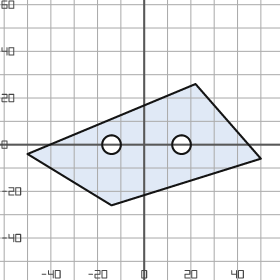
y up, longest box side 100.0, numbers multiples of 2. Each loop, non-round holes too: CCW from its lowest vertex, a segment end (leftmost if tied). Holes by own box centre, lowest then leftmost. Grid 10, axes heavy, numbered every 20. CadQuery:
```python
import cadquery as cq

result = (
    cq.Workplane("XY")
    .moveTo(-14.0, -26.0)
    .lineTo(50.0, -6.0)
    .lineTo(22.0, 26.0)
    .lineTo(-50.0, -4.0)
    .close()
    .moveTo(-14.0, 0.0)
    .circle(4.0)
    .moveTo(16.0, 0.0)
    .circle(4.0)
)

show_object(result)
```